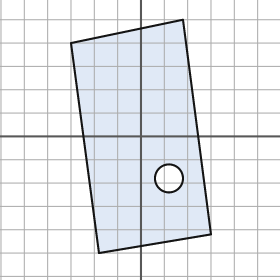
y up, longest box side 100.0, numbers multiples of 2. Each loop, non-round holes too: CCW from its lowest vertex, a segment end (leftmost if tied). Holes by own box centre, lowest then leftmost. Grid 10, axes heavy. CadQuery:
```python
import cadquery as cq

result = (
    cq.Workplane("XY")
    .moveTo(-18.0, -50.0)
    .lineTo(30.0, -42.0)
    .lineTo(18.0, 50.0)
    .lineTo(-30.0, 40.0)
    .close()
    .moveTo(12.0, -18.0)
    .circle(6.0)
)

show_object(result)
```